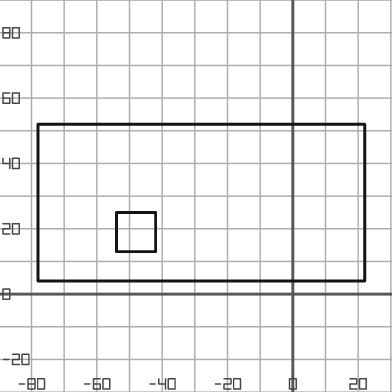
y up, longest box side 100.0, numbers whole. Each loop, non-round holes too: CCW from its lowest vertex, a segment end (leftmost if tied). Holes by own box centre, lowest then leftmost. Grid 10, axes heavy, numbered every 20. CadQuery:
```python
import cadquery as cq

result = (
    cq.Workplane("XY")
    .moveTo(-78.0, 4.0)
    .lineTo(22.0, 4.0)
    .lineTo(22.0, 52.0)
    .lineTo(-78.0, 52.0)
    .close()
    .moveTo(-54.0, 13.0)
    .lineTo(-42.0, 13.0)
    .lineTo(-42.0, 25.0)
    .lineTo(-54.0, 25.0)
    .close()
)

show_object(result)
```